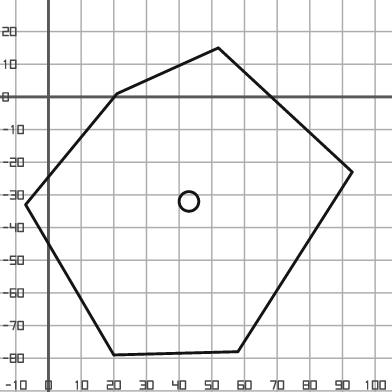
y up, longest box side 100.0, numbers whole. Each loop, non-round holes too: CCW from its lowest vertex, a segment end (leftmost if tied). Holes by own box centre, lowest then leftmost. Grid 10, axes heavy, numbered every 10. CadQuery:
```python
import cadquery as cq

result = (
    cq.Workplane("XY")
    .moveTo(20.0, -79.0)
    .lineTo(58.0, -78.0)
    .lineTo(93.0, -23.0)
    .lineTo(52.0, 15.0)
    .lineTo(21.0, 1.0)
    .lineTo(-7.0, -33.0)
    .close()
    .moveTo(43.0, -32.0)
    .circle(3.0)
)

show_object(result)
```